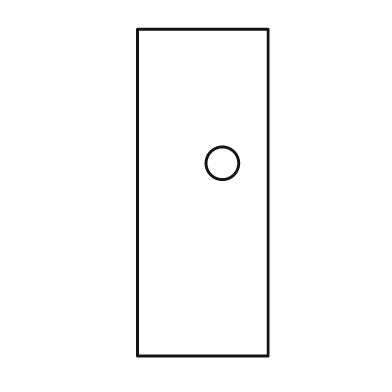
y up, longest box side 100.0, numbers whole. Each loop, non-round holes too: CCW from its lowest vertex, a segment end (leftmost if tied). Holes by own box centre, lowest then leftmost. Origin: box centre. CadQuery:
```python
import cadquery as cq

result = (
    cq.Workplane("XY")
    .moveTo(-20.0, -50.0)
    .lineTo(20.0, -50.0)
    .lineTo(20.0, 50.0)
    .lineTo(-20.0, 50.0)
    .close()
    .moveTo(6.0, 9.0)
    .circle(5.0)
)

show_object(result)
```